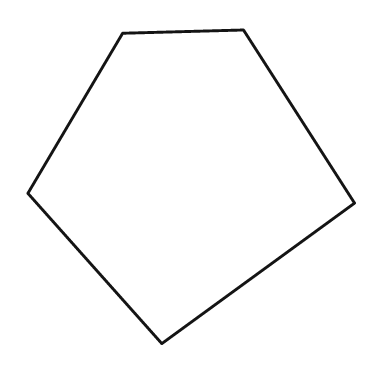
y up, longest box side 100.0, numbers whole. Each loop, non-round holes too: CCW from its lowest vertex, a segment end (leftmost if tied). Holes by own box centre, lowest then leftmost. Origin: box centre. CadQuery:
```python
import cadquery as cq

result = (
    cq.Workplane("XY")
    .moveTo(-9.0, -48.0)
    .lineTo(50.0, -5.0)
    .lineTo(16.0, 48.0)
    .lineTo(-21.0, 47.0)
    .lineTo(-50.0, -2.0)
    .close()
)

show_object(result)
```